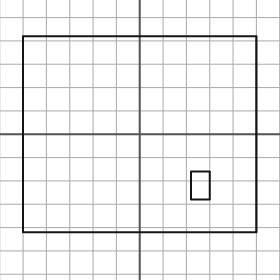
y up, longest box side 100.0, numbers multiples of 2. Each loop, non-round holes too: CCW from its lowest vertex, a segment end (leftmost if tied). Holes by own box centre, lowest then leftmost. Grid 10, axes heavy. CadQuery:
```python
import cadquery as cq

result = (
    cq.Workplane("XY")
    .moveTo(-50.0, -42.0)
    .lineTo(50.0, -42.0)
    .lineTo(50.0, 42.0)
    .lineTo(-50.0, 42.0)
    .close()
    .moveTo(22.0, -28.0)
    .lineTo(30.0, -28.0)
    .lineTo(30.0, -16.0)
    .lineTo(22.0, -16.0)
    .close()
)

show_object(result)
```